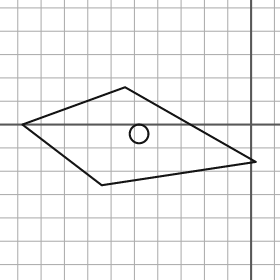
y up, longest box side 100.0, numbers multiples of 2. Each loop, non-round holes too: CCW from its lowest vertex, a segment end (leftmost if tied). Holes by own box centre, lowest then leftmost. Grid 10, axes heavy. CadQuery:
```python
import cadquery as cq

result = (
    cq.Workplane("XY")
    .moveTo(-64.0, -26.0)
    .lineTo(2.0, -16.0)
    .lineTo(-54.0, 16.0)
    .lineTo(-98.0, 0.0)
    .close()
    .moveTo(-48.0, -4.0)
    .circle(4.0)
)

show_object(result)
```